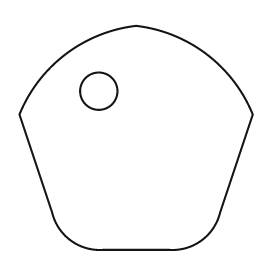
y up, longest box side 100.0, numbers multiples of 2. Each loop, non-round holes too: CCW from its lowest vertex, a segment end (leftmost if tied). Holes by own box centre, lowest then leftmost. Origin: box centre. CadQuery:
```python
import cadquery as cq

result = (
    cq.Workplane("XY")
    .moveTo(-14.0, -48.0)
    .lineTo(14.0, -48.0)
    .threePointArc((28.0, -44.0), (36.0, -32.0))
    .lineTo(50.0, 10.0)
    .threePointArc((30.0, 36.0), (0.0, 48.0))
    .threePointArc((-30.0, 36.0), (-50.0, 10.0))
    .lineTo(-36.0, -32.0)
    .threePointArc((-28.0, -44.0), (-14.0, -48.0))
    .close()
    .moveTo(-16.0, 20.0)
    .circle(8.0)
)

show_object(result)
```